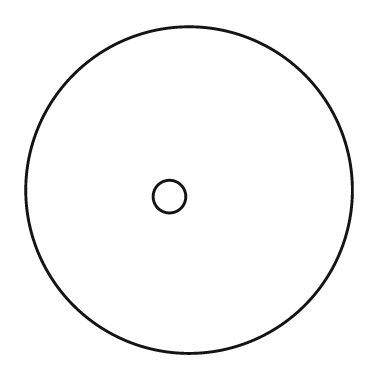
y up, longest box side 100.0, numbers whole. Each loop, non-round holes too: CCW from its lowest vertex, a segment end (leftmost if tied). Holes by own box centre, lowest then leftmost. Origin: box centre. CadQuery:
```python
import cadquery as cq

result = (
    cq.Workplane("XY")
    .moveTo(0.0, 0.0)
    .circle(50.0)
    .moveTo(-6.0, -2.0)
    .circle(5.0)
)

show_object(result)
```